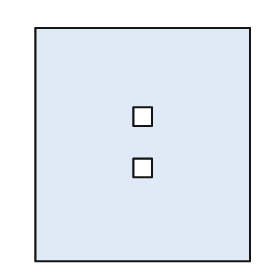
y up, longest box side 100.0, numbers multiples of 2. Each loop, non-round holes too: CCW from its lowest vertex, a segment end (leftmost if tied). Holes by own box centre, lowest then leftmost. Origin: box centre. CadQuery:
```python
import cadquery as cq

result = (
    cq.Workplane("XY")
    .moveTo(-46.0, -50.0)
    .lineTo(46.0, -50.0)
    .lineTo(46.0, 50.0)
    .lineTo(-46.0, 50.0)
    .close()
    .moveTo(-4.0, -14.0)
    .lineTo(4.0, -14.0)
    .lineTo(4.0, -6.0)
    .lineTo(-4.0, -6.0)
    .close()
    .moveTo(-4.0, 8.0)
    .lineTo(4.0, 8.0)
    .lineTo(4.0, 16.0)
    .lineTo(-4.0, 16.0)
    .close()
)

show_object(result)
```